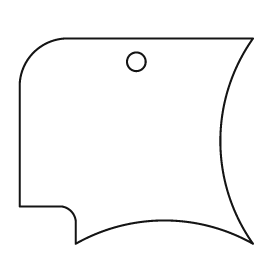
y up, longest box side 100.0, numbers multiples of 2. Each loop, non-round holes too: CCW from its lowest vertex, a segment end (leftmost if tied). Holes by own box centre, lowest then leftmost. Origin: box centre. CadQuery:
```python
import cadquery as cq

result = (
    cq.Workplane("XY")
    .moveTo(-26.0, -44.0)
    .threePointArc((12.0, -34.0), (50.0, -44.0))
    .threePointArc((36.0, 0.0), (50.0, 44.0))
    .lineTo(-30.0, 44.0)
    .threePointArc((-44.0, 38.0), (-50.0, 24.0))
    .lineTo(-50.0, -28.0)
    .lineTo(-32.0, -28.0)
    .threePointArc((-28.0, -30.0), (-26.0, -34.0))
    .close()
    .moveTo(0.0, 34.0)
    .circle(4.0)
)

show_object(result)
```